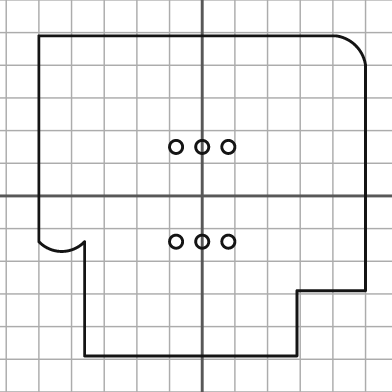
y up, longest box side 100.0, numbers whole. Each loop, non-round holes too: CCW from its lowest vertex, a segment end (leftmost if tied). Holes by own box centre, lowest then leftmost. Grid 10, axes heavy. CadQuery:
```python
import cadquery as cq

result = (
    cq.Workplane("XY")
    .moveTo(-36.0, -49.0)
    .lineTo(29.0, -49.0)
    .lineTo(29.0, -29.0)
    .lineTo(50.0, -29.0)
    .lineTo(50.0, 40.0)
    .threePointArc((47.0, 46.0), (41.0, 49.0))
    .lineTo(-50.0, 49.0)
    .lineTo(-50.0, -14.0)
    .threePointArc((-43.0, -17.0), (-36.0, -14.0))
    .close()
    .moveTo(-8.0, -14.0)
    .circle(2.0)
    .moveTo(0.0, -14.0)
    .circle(2.0)
    .moveTo(8.0, -14.0)
    .circle(2.0)
    .moveTo(-8.0, 15.0)
    .circle(2.0)
    .moveTo(0.0, 15.0)
    .circle(2.0)
    .moveTo(8.0, 15.0)
    .circle(2.0)
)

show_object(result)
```